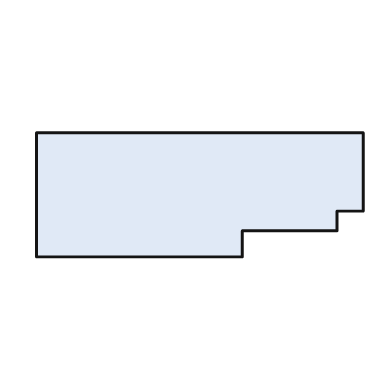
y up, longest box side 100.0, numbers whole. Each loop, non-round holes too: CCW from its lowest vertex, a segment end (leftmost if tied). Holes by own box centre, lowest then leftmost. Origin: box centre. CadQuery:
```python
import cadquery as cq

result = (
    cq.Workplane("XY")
    .moveTo(-50.0, -19.0)
    .lineTo(13.0, -19.0)
    .lineTo(13.0, -11.0)
    .lineTo(42.0, -11.0)
    .lineTo(42.0, -5.0)
    .lineTo(50.0, -5.0)
    .lineTo(50.0, 19.0)
    .lineTo(-50.0, 19.0)
    .close()
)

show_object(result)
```